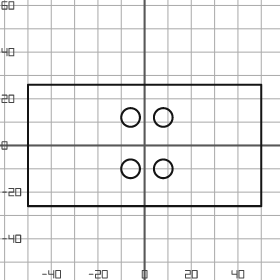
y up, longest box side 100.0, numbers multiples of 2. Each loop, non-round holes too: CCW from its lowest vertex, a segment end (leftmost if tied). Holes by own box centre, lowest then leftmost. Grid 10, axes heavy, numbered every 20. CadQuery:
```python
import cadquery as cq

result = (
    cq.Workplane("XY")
    .moveTo(-50.0, -26.0)
    .lineTo(50.0, -26.0)
    .lineTo(50.0, 26.0)
    .lineTo(-50.0, 26.0)
    .close()
    .moveTo(-6.0, -10.0)
    .circle(4.0)
    .moveTo(8.0, -10.0)
    .circle(4.0)
    .moveTo(-6.0, 12.0)
    .circle(4.0)
    .moveTo(8.0, 12.0)
    .circle(4.0)
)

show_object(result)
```